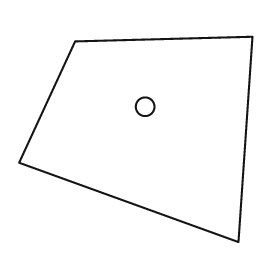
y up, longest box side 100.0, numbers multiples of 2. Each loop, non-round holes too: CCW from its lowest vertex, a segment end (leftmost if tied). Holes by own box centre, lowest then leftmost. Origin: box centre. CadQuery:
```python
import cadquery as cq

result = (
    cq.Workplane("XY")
    .moveTo(44.0, -44.0)
    .lineTo(50.0, 44.0)
    .lineTo(-26.0, 42.0)
    .lineTo(-50.0, -10.0)
    .close()
    .moveTo(4.0, 14.0)
    .circle(4.0)
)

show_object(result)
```